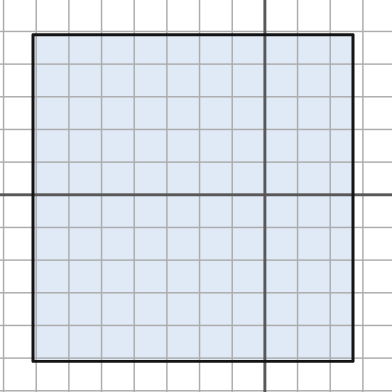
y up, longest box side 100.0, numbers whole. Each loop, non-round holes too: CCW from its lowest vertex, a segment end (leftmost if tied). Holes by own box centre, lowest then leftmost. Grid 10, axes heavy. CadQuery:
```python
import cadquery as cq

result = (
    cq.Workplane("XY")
    .moveTo(-71.0, -51.0)
    .lineTo(27.0, -51.0)
    .lineTo(27.0, 49.0)
    .lineTo(-71.0, 49.0)
    .close()
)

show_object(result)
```